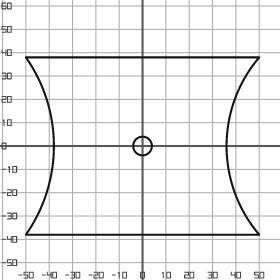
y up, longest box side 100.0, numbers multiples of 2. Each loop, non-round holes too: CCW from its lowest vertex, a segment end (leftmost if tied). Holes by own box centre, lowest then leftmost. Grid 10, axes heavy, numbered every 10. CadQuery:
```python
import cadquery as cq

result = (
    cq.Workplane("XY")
    .moveTo(-50.0, -38.0)
    .lineTo(50.0, -38.0)
    .threePointArc((36.0, 0.0), (50.0, 38.0))
    .lineTo(-50.0, 38.0)
    .threePointArc((-38.0, 0.0), (-50.0, -38.0))
    .close()
    .moveTo(0.0, 0.0)
    .circle(4.0)
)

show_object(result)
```